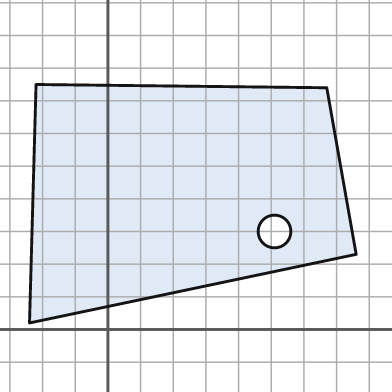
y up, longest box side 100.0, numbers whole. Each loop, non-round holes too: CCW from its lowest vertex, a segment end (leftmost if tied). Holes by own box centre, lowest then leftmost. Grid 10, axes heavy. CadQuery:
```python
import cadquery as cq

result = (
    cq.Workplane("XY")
    .moveTo(-24.0, 2.0)
    .lineTo(76.0, 23.0)
    .lineTo(67.0, 74.0)
    .lineTo(-22.0, 75.0)
    .close()
    .moveTo(51.0, 30.0)
    .circle(5.0)
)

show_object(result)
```